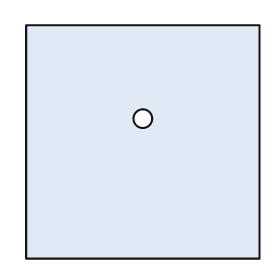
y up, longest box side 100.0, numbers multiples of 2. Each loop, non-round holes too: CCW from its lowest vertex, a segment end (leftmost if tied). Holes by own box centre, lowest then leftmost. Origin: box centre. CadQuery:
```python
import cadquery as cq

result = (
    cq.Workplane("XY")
    .moveTo(-50.0, -50.0)
    .lineTo(50.0, -50.0)
    .lineTo(50.0, 50.0)
    .lineTo(-50.0, 50.0)
    .close()
    .moveTo(0.0, 10.0)
    .circle(4.0)
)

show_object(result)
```